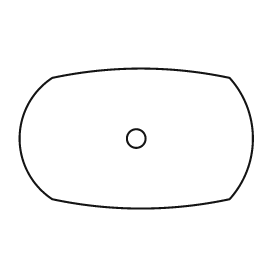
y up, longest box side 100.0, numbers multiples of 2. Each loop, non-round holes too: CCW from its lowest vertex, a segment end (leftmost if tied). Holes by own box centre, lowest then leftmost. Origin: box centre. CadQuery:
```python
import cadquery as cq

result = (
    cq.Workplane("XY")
    .moveTo(-36.0, -26.0)
    .threePointArc((2.0, -30.0), (40.0, -26.0))
    .threePointArc((50.0, 0.0), (40.0, 26.0))
    .threePointArc((2.0, 30.0), (-36.0, 26.0))
    .threePointArc((-50.0, 0.0), (-36.0, -26.0))
    .close()
    .moveTo(0.0, 0.0)
    .circle(4.0)
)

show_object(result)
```